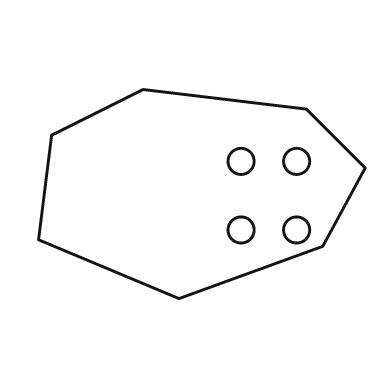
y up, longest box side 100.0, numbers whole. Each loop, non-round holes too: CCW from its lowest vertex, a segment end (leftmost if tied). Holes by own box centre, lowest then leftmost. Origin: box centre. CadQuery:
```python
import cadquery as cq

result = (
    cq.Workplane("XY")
    .moveTo(-7.0, -32.0)
    .lineTo(37.0, -16.0)
    .lineTo(50.0, 8.0)
    .lineTo(32.0, 26.0)
    .lineTo(-18.0, 32.0)
    .lineTo(-46.0, 18.0)
    .lineTo(-50.0, -14.0)
    .close()
    .moveTo(12.0, -11.0)
    .circle(4.0)
    .moveTo(29.0, -11.0)
    .circle(4.0)
    .moveTo(12.0, 10.0)
    .circle(4.0)
    .moveTo(29.0, 10.0)
    .circle(4.0)
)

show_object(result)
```